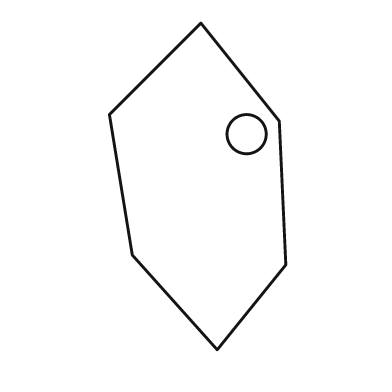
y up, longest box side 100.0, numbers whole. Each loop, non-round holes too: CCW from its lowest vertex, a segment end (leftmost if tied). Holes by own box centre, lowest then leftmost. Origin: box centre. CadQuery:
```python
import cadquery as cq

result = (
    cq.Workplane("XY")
    .moveTo(6.0, -50.0)
    .lineTo(27.0, -24.0)
    .lineTo(25.0, 20.0)
    .lineTo(1.0, 50.0)
    .lineTo(-27.0, 22.0)
    .lineTo(-20.0, -21.0)
    .close()
    .moveTo(15.0, 16.0)
    .circle(6.0)
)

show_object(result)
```